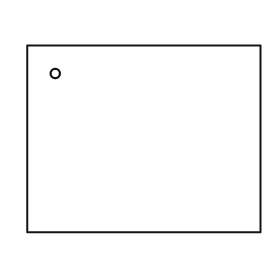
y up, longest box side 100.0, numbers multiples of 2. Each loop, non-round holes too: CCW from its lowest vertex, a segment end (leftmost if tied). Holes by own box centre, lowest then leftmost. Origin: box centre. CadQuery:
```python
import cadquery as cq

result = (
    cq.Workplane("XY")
    .moveTo(-50.0, -40.0)
    .lineTo(50.0, -40.0)
    .lineTo(50.0, 40.0)
    .lineTo(-50.0, 40.0)
    .close()
    .moveTo(-38.0, 28.0)
    .circle(2.0)
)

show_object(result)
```